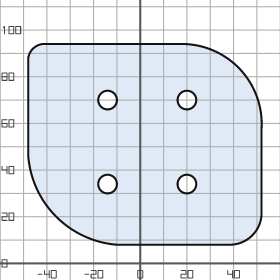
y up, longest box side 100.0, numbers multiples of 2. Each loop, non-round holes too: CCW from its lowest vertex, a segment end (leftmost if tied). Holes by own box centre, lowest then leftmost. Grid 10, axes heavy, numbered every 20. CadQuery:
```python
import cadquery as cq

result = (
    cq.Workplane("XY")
    .moveTo(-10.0, 8.0)
    .lineTo(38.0, 8.0)
    .threePointArc((48.0, 12.0), (52.0, 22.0))
    .lineTo(52.0, 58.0)
    .threePointArc((42.0, 84.0), (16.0, 94.0))
    .lineTo(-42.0, 94.0)
    .threePointArc((-46.0, 92.0), (-48.0, 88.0))
    .lineTo(-48.0, 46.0)
    .threePointArc((-36.0, 20.0), (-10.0, 8.0))
    .close()
    .moveTo(-14.0, 34.0)
    .circle(4.0)
    .moveTo(20.0, 34.0)
    .circle(4.0)
    .moveTo(-14.0, 70.0)
    .circle(4.0)
    .moveTo(20.0, 70.0)
    .circle(4.0)
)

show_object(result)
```